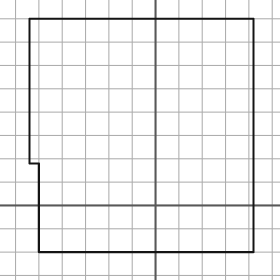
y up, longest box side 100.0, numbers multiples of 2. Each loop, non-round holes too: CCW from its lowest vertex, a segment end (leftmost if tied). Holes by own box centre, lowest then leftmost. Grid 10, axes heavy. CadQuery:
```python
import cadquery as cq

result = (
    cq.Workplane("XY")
    .moveTo(-50.0, -20.0)
    .lineTo(42.0, -20.0)
    .lineTo(42.0, 80.0)
    .lineTo(-54.0, 80.0)
    .lineTo(-54.0, 18.0)
    .lineTo(-50.0, 18.0)
    .close()
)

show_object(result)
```